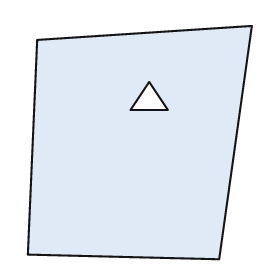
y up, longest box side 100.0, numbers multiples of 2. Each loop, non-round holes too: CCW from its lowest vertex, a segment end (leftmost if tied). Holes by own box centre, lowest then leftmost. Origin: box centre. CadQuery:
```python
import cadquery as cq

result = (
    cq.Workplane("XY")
    .moveTo(34.0, -50.0)
    .lineTo(48.0, 50.0)
    .lineTo(-44.0, 44.0)
    .lineTo(-48.0, -48.0)
    .close()
    .moveTo(-4.0, 14.0)
    .lineTo(12.0, 14.0)
    .lineTo(4.0, 26.0)
    .close()
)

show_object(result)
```